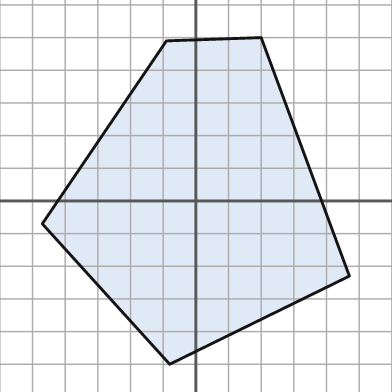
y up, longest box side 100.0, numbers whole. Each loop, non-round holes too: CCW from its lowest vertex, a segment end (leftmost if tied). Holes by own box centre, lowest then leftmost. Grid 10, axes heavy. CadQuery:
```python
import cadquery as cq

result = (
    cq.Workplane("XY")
    .moveTo(-8.0, -50.0)
    .lineTo(47.0, -23.0)
    .lineTo(20.0, 50.0)
    .lineTo(-9.0, 49.0)
    .lineTo(-47.0, -7.0)
    .close()
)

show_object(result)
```